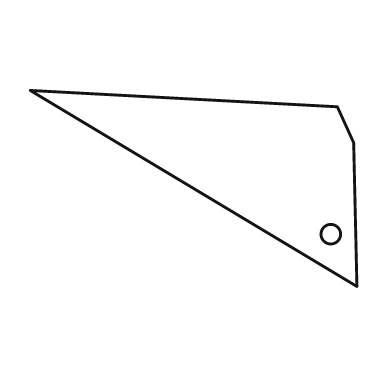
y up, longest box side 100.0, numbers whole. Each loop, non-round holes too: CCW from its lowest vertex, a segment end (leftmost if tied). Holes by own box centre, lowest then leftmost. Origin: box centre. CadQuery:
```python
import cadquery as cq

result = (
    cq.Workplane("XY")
    .moveTo(50.0, -30.0)
    .lineTo(49.0, 14.0)
    .lineTo(44.0, 25.0)
    .lineTo(-50.0, 30.0)
    .close()
    .moveTo(42.0, -14.0)
    .circle(3.0)
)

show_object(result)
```